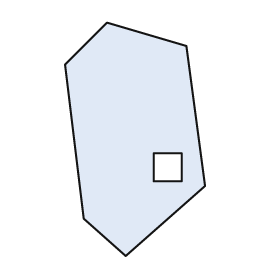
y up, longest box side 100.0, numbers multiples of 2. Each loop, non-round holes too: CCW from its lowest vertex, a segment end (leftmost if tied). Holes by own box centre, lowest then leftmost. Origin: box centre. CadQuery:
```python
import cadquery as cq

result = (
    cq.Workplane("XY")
    .moveTo(-4.0, -50.0)
    .lineTo(30.0, -20.0)
    .lineTo(22.0, 40.0)
    .lineTo(-12.0, 50.0)
    .lineTo(-30.0, 32.0)
    .lineTo(-22.0, -34.0)
    .close()
    .moveTo(8.0, -18.0)
    .lineTo(20.0, -18.0)
    .lineTo(20.0, -6.0)
    .lineTo(8.0, -6.0)
    .close()
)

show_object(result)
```